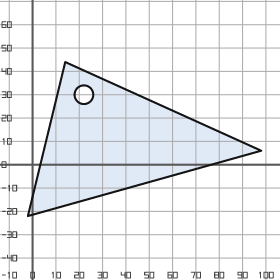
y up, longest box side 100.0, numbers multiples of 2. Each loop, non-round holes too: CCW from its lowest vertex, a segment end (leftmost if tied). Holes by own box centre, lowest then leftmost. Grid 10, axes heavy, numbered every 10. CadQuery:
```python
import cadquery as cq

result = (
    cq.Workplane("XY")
    .moveTo(-2.0, -22.0)
    .lineTo(98.0, 6.0)
    .lineTo(14.0, 44.0)
    .close()
    .moveTo(22.0, 30.0)
    .circle(4.0)
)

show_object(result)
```